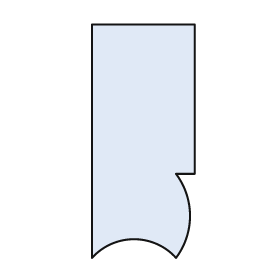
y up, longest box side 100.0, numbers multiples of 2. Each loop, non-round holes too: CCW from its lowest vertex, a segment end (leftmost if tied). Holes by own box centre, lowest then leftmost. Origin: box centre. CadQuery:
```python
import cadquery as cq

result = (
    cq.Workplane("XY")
    .moveTo(-22.0, -50.0)
    .threePointArc((-4.0, -42.0), (14.0, -50.0))
    .threePointArc((20.0, -32.0), (14.0, -14.0))
    .lineTo(22.0, -14.0)
    .lineTo(22.0, 50.0)
    .lineTo(-22.0, 50.0)
    .close()
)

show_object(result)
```